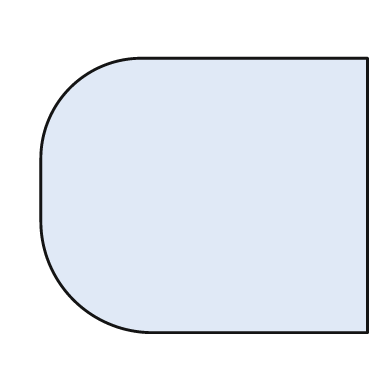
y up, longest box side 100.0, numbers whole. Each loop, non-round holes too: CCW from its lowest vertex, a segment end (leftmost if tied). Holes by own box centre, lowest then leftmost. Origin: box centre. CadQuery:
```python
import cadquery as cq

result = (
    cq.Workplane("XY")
    .moveTo(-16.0, -42.0)
    .lineTo(50.0, -42.0)
    .lineTo(50.0, 42.0)
    .lineTo(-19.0, 42.0)
    .threePointArc((-41.0, 33.0), (-50.0, 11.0))
    .lineTo(-50.0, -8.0)
    .threePointArc((-40.0, -32.0), (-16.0, -42.0))
    .close()
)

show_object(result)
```